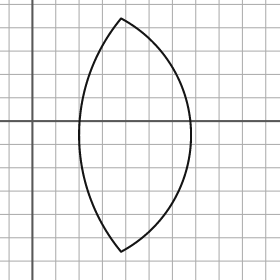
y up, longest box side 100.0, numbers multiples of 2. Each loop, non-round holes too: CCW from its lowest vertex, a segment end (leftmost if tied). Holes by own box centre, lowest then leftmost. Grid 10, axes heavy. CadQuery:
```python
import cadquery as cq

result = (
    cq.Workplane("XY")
    .moveTo(38.0, -56.0)
    .threePointArc((68.0, -6.0), (38.0, 44.0))
    .threePointArc((20.0, -6.0), (38.0, -56.0))
    .close()
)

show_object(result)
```